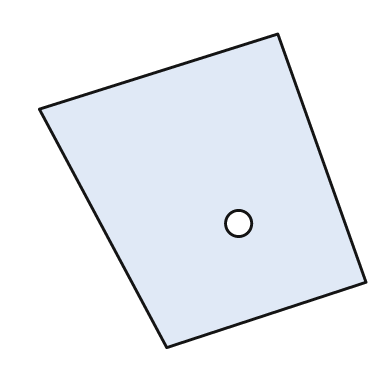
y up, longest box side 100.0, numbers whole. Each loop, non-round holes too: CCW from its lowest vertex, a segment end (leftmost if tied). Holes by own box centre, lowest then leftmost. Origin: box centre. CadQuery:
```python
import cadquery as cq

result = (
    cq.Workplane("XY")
    .moveTo(-11.0, -48.0)
    .lineTo(50.0, -28.0)
    .lineTo(23.0, 48.0)
    .lineTo(-50.0, 25.0)
    .close()
    .moveTo(11.0, -10.0)
    .circle(4.0)
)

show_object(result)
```